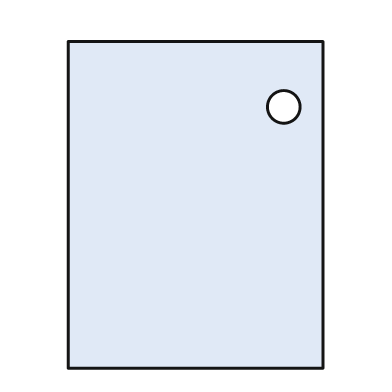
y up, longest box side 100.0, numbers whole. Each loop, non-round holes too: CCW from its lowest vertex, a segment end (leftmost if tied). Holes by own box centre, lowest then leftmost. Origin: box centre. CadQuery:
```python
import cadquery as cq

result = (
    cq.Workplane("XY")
    .moveTo(-39.0, -50.0)
    .lineTo(39.0, -50.0)
    .lineTo(39.0, 50.0)
    .lineTo(-39.0, 50.0)
    .close()
    .moveTo(27.0, 30.0)
    .circle(5.0)
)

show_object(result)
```